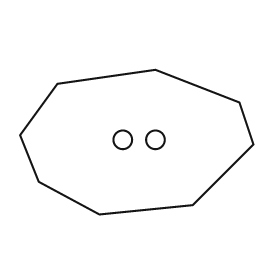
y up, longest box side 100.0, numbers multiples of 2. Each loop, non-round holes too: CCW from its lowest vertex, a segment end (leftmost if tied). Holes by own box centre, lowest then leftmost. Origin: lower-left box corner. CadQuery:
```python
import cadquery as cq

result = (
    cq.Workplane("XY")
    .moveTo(34.0, 0.0)
    .lineTo(74.0, 4.0)
    .lineTo(100.0, 30.0)
    .lineTo(94.0, 48.0)
    .lineTo(58.0, 62.0)
    .lineTo(16.0, 56.0)
    .lineTo(0.0, 34.0)
    .lineTo(8.0, 14.0)
    .close()
    .moveTo(44.0, 32.0)
    .circle(4.0)
    .moveTo(58.0, 32.0)
    .circle(4.0)
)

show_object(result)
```